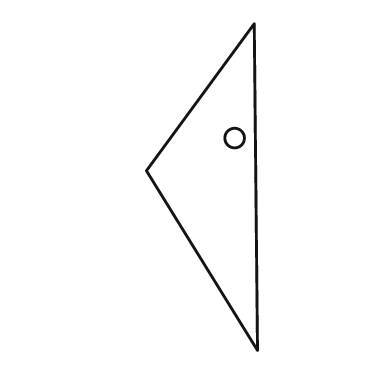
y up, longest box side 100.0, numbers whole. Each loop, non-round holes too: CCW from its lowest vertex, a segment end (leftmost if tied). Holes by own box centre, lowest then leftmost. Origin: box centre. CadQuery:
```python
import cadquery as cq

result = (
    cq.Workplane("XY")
    .moveTo(17.0, -50.0)
    .lineTo(16.0, 50.0)
    .lineTo(-17.0, 5.0)
    .close()
    .moveTo(10.0, 15.0)
    .circle(3.0)
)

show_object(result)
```